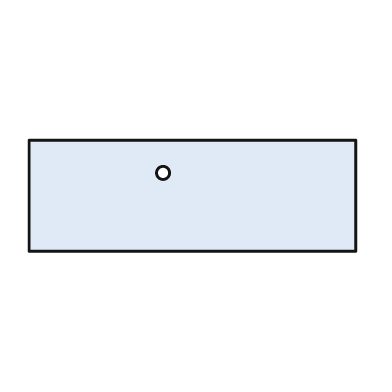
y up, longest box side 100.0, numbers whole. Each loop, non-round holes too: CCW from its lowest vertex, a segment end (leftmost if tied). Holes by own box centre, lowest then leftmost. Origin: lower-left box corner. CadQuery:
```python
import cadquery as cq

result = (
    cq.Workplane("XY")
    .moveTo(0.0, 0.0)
    .lineTo(100.0, 0.0)
    .lineTo(100.0, 34.0)
    .lineTo(0.0, 34.0)
    .close()
    .moveTo(41.0, 24.0)
    .circle(2.0)
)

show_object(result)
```